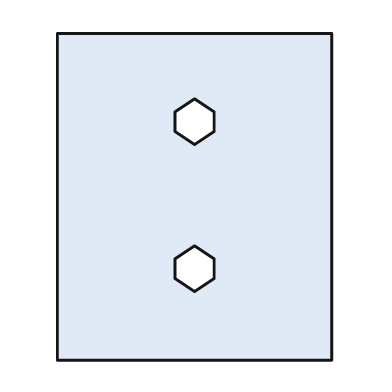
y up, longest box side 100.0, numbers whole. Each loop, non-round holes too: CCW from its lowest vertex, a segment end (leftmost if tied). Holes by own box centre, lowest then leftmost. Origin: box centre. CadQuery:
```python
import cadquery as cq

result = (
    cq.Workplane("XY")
    .moveTo(-42.0, -50.0)
    .lineTo(42.0, -50.0)
    .lineTo(42.0, 50.0)
    .lineTo(-42.0, 50.0)
    .close()
    .moveTo(0.0, -29.0)
    .lineTo(6.0, -25.0)
    .lineTo(6.0, -19.0)
    .lineTo(0.0, -15.0)
    .lineTo(-6.0, -19.0)
    .lineTo(-6.0, -25.0)
    .close()
    .moveTo(0.0, 16.0)
    .lineTo(6.0, 20.0)
    .lineTo(6.0, 26.0)
    .lineTo(0.0, 30.0)
    .lineTo(-6.0, 26.0)
    .lineTo(-6.0, 20.0)
    .close()
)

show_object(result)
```